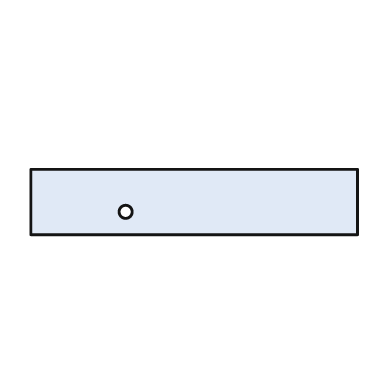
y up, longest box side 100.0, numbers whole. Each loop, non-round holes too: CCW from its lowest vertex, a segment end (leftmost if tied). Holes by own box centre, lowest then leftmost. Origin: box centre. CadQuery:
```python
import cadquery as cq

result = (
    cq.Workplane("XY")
    .moveTo(-50.0, -10.0)
    .lineTo(50.0, -10.0)
    .lineTo(50.0, 10.0)
    .lineTo(-50.0, 10.0)
    .close()
    .moveTo(-21.0, -3.0)
    .circle(2.0)
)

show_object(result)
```